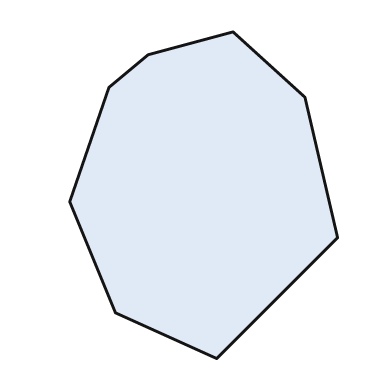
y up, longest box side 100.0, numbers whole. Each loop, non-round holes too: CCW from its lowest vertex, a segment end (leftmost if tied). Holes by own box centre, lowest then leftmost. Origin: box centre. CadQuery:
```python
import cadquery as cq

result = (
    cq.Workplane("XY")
    .moveTo(4.0, -50.0)
    .lineTo(41.0, -13.0)
    .lineTo(31.0, 30.0)
    .lineTo(9.0, 50.0)
    .lineTo(-17.0, 43.0)
    .lineTo(-29.0, 33.0)
    .lineTo(-41.0, -2.0)
    .lineTo(-27.0, -36.0)
    .close()
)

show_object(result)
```